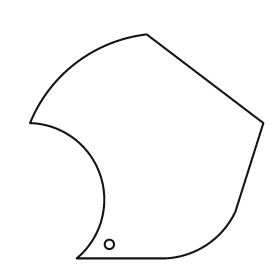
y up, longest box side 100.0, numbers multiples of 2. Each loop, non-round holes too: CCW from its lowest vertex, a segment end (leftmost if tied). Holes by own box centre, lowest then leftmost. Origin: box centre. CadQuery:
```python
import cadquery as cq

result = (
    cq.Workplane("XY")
    .moveTo(-30.0, -48.0)
    .lineTo(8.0, -48.0)
    .threePointArc((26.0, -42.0), (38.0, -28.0))
    .lineTo(50.0, 10.0)
    .lineTo(0.0, 48.0)
    .threePointArc((-30.0, 36.0), (-50.0, 10.0))
    .threePointArc((-20.0, -12.0), (-30.0, -48.0))
    .close()
    .moveTo(-16.0, -42.0)
    .circle(2.0)
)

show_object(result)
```